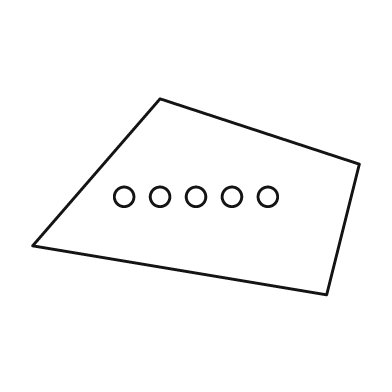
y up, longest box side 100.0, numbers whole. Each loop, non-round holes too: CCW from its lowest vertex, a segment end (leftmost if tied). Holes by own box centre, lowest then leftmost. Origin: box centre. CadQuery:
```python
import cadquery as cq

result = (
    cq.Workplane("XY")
    .moveTo(40.0, -30.0)
    .lineTo(50.0, 10.0)
    .lineTo(-11.0, 30.0)
    .lineTo(-50.0, -15.0)
    .close()
    .moveTo(-22.0, 0.0)
    .circle(3.0)
    .moveTo(-11.0, 0.0)
    .circle(3.0)
    .moveTo(0.0, 0.0)
    .circle(3.0)
    .moveTo(11.0, 0.0)
    .circle(3.0)
    .moveTo(22.0, 0.0)
    .circle(3.0)
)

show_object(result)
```